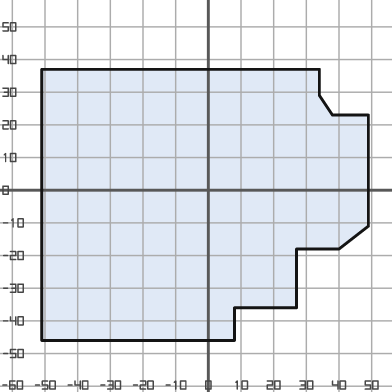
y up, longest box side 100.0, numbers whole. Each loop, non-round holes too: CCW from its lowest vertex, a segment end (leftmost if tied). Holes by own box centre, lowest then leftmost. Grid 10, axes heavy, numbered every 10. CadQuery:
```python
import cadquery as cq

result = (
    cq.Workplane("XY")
    .moveTo(-51.0, -46.0)
    .lineTo(8.0, -46.0)
    .lineTo(8.0, -36.0)
    .lineTo(27.0, -36.0)
    .lineTo(27.0, -18.0)
    .lineTo(40.0, -18.0)
    .lineTo(49.0, -11.0)
    .lineTo(49.0, 23.0)
    .lineTo(38.0, 23.0)
    .lineTo(34.0, 29.0)
    .lineTo(34.0, 37.0)
    .lineTo(-51.0, 37.0)
    .close()
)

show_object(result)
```